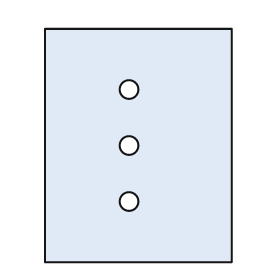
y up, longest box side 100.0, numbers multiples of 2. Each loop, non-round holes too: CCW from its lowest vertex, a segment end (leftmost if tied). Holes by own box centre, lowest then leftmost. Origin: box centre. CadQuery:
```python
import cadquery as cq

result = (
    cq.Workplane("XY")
    .moveTo(-40.0, -50.0)
    .lineTo(40.0, -50.0)
    .lineTo(40.0, 50.0)
    .lineTo(-40.0, 50.0)
    .close()
    .moveTo(-4.0, -24.0)
    .circle(4.0)
    .moveTo(-4.0, 0.0)
    .circle(4.0)
    .moveTo(-4.0, 24.0)
    .circle(4.0)
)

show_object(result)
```